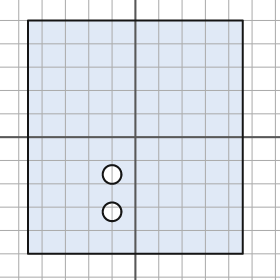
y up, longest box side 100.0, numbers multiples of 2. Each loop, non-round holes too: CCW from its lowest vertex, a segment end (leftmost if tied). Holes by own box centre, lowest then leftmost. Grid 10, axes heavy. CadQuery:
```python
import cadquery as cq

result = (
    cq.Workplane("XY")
    .moveTo(-46.0, -50.0)
    .lineTo(46.0, -50.0)
    .lineTo(46.0, 50.0)
    .lineTo(-46.0, 50.0)
    .close()
    .moveTo(-10.0, -32.0)
    .circle(4.0)
    .moveTo(-10.0, -16.0)
    .circle(4.0)
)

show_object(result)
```